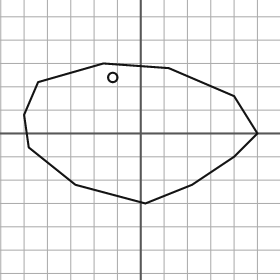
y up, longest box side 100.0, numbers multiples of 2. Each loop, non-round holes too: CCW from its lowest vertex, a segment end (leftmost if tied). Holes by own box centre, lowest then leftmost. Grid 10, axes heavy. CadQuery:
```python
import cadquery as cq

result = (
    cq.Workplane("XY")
    .moveTo(2.0, -30.0)
    .lineTo(22.0, -22.0)
    .lineTo(40.0, -10.0)
    .lineTo(50.0, 0.0)
    .lineTo(40.0, 16.0)
    .lineTo(12.0, 28.0)
    .lineTo(-16.0, 30.0)
    .lineTo(-44.0, 22.0)
    .lineTo(-50.0, 8.0)
    .lineTo(-48.0, -6.0)
    .lineTo(-28.0, -22.0)
    .close()
    .moveTo(-12.0, 24.0)
    .circle(2.0)
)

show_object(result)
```